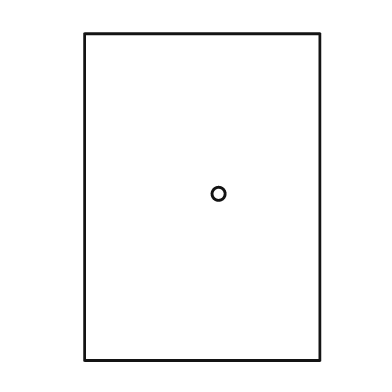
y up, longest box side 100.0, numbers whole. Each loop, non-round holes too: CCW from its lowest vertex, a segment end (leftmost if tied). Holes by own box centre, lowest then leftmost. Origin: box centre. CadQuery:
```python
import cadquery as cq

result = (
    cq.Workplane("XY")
    .moveTo(-36.0, -50.0)
    .lineTo(36.0, -50.0)
    .lineTo(36.0, 50.0)
    .lineTo(-36.0, 50.0)
    .close()
    .moveTo(5.0, 1.0)
    .circle(2.0)
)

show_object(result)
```